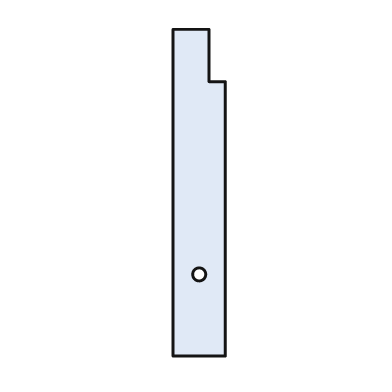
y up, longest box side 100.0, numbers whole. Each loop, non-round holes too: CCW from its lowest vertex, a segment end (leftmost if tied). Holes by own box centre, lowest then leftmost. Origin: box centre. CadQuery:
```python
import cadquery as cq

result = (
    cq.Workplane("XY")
    .moveTo(-8.0, -50.0)
    .lineTo(8.0, -50.0)
    .lineTo(8.0, 34.0)
    .lineTo(3.0, 34.0)
    .lineTo(3.0, 50.0)
    .lineTo(-8.0, 50.0)
    .close()
    .moveTo(0.0, -25.0)
    .circle(2.0)
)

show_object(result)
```